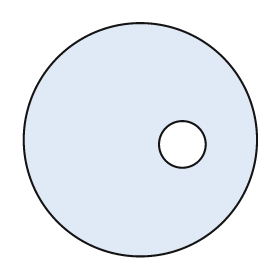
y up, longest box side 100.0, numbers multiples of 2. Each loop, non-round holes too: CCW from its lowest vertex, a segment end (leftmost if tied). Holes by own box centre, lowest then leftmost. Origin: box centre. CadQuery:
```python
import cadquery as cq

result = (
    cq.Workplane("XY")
    .moveTo(0.0, 0.0)
    .circle(50.0)
    .moveTo(18.0, -2.0)
    .circle(10.0)
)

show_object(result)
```